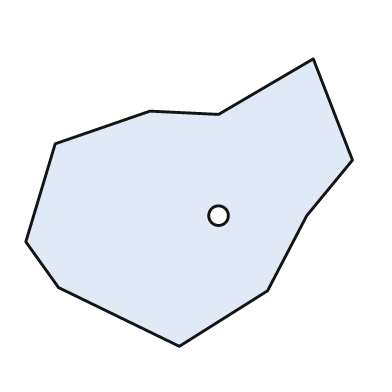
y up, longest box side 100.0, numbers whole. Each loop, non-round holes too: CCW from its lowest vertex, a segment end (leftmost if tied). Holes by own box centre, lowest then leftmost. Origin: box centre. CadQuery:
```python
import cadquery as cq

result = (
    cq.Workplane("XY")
    .moveTo(-3.0, -44.0)
    .lineTo(24.0, -27.0)
    .lineTo(36.0, -4.0)
    .lineTo(50.0, 13.0)
    .lineTo(38.0, 44.0)
    .lineTo(9.0, 27.0)
    .lineTo(-12.0, 28.0)
    .lineTo(-41.0, 18.0)
    .lineTo(-50.0, -12.0)
    .lineTo(-40.0, -26.0)
    .close()
    .moveTo(9.0, -4.0)
    .circle(3.0)
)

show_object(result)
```